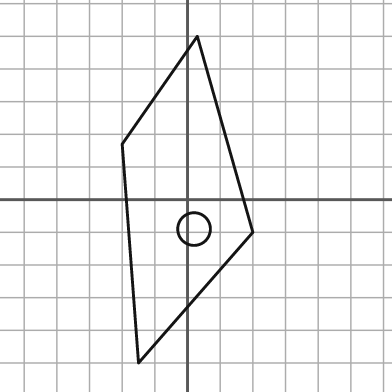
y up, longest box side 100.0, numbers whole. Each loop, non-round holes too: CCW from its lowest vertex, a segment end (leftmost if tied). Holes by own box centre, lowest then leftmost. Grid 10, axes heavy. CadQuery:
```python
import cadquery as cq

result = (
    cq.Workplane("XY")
    .moveTo(-15.0, -50.0)
    .lineTo(20.0, -10.0)
    .lineTo(3.0, 50.0)
    .lineTo(-20.0, 17.0)
    .close()
    .moveTo(2.0, -9.0)
    .circle(5.0)
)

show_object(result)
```